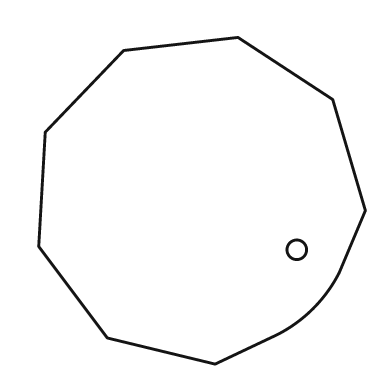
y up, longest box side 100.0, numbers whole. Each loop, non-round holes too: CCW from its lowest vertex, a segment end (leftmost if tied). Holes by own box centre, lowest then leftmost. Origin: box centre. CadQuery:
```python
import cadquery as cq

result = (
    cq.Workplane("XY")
    .moveTo(4.0, -50.0)
    .lineTo(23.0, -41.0)
    .threePointArc((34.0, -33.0), (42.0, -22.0))
    .lineTo(50.0, -3.0)
    .lineTo(40.0, 31.0)
    .lineTo(11.0, 50.0)
    .lineTo(-24.0, 46.0)
    .lineTo(-48.0, 21.0)
    .lineTo(-50.0, -14.0)
    .lineTo(-29.0, -42.0)
    .close()
    .moveTo(29.0, -15.0)
    .circle(3.0)
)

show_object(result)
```